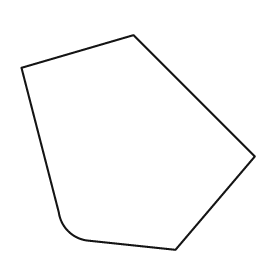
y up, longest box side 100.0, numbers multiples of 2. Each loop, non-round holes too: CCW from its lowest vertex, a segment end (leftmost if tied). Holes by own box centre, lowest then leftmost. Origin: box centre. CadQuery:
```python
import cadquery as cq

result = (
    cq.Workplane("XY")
    .moveTo(16.0, -46.0)
    .lineTo(50.0, -6.0)
    .lineTo(-2.0, 46.0)
    .lineTo(-50.0, 32.0)
    .lineTo(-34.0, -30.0)
    .threePointArc((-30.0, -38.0), (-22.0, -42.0))
    .close()
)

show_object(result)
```